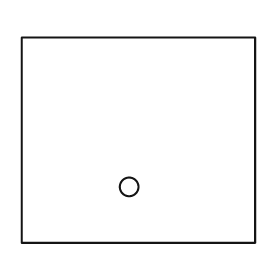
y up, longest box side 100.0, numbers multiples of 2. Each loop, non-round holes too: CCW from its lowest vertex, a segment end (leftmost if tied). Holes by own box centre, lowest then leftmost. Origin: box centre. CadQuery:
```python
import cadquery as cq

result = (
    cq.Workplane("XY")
    .moveTo(-50.0, -44.0)
    .lineTo(50.0, -44.0)
    .lineTo(50.0, 44.0)
    .lineTo(-50.0, 44.0)
    .close()
    .moveTo(-4.0, -20.0)
    .circle(4.0)
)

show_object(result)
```